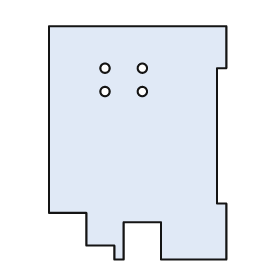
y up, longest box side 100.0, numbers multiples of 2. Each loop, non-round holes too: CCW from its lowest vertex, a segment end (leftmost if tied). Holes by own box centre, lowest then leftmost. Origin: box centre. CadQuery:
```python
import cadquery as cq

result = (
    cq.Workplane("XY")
    .moveTo(-10.0, -50.0)
    .lineTo(-6.0, -50.0)
    .lineTo(-6.0, -34.0)
    .lineTo(10.0, -34.0)
    .lineTo(10.0, -50.0)
    .lineTo(38.0, -50.0)
    .lineTo(38.0, -26.0)
    .lineTo(34.0, -26.0)
    .lineTo(34.0, 32.0)
    .lineTo(38.0, 32.0)
    .lineTo(38.0, 50.0)
    .lineTo(-38.0, 50.0)
    .lineTo(-38.0, -30.0)
    .lineTo(-22.0, -30.0)
    .lineTo(-22.0, -44.0)
    .lineTo(-10.0, -44.0)
    .close()
    .moveTo(-14.0, 22.0)
    .circle(2.0)
    .moveTo(2.0, 22.0)
    .circle(2.0)
    .moveTo(-14.0, 32.0)
    .circle(2.0)
    .moveTo(2.0, 32.0)
    .circle(2.0)
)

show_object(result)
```